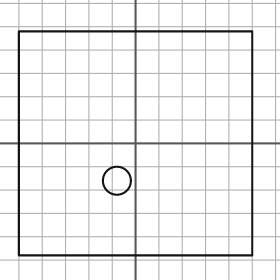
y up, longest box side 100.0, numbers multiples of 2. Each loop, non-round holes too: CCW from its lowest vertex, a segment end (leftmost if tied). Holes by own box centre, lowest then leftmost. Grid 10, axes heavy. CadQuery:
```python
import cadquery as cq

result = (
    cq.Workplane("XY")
    .moveTo(-50.0, -48.0)
    .lineTo(50.0, -48.0)
    .lineTo(50.0, 48.0)
    .lineTo(-50.0, 48.0)
    .close()
    .moveTo(-8.0, -16.0)
    .circle(6.0)
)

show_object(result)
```